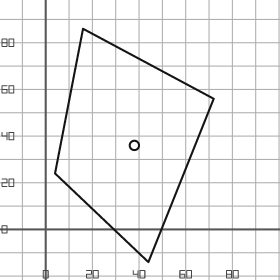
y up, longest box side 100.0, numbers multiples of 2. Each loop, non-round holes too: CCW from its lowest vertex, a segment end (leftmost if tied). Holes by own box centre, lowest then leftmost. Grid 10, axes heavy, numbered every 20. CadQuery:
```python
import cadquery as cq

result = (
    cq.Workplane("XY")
    .moveTo(44.0, -14.0)
    .lineTo(72.0, 56.0)
    .lineTo(16.0, 86.0)
    .lineTo(4.0, 24.0)
    .close()
    .moveTo(38.0, 36.0)
    .circle(2.0)
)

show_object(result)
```